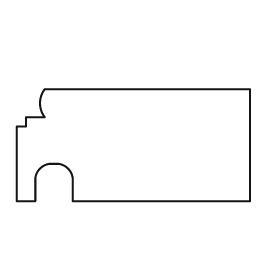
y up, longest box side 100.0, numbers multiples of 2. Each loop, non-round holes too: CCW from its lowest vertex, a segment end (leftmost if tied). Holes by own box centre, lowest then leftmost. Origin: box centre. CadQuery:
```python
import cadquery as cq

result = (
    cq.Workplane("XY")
    .moveTo(-50.0, -24.0)
    .lineTo(-42.0, -24.0)
    .lineTo(-42.0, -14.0)
    .threePointArc((-40.0, -10.0), (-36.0, -8.0))
    .lineTo(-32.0, -8.0)
    .threePointArc((-28.0, -10.0), (-26.0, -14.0))
    .lineTo(-26.0, -24.0)
    .lineTo(50.0, -24.0)
    .lineTo(50.0, 24.0)
    .lineTo(-38.0, 24.0)
    .threePointArc((-40.0, 18.0), (-38.0, 12.0))
    .lineTo(-46.0, 12.0)
    .lineTo(-46.0, 8.0)
    .lineTo(-50.0, 8.0)
    .close()
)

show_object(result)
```